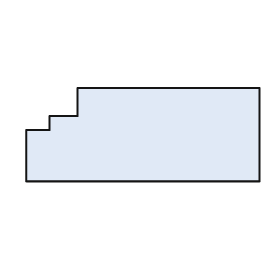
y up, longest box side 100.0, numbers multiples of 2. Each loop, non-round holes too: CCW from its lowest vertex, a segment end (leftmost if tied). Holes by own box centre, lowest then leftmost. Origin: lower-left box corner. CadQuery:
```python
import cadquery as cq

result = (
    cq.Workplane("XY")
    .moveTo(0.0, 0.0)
    .lineTo(100.0, 0.0)
    .lineTo(100.0, 40.0)
    .lineTo(22.0, 40.0)
    .lineTo(22.0, 28.0)
    .lineTo(10.0, 28.0)
    .lineTo(10.0, 22.0)
    .lineTo(0.0, 22.0)
    .close()
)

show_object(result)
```